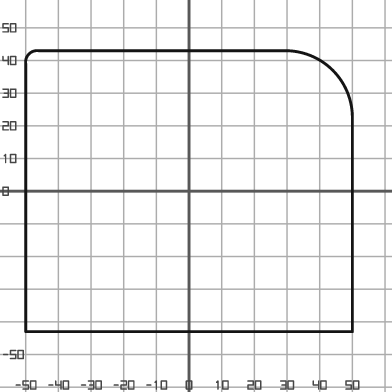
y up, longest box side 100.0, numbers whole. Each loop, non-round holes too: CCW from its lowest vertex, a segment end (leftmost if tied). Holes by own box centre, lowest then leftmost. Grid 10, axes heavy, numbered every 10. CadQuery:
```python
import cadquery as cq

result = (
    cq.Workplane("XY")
    .moveTo(-50.0, -43.0)
    .lineTo(50.0, -43.0)
    .lineTo(50.0, 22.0)
    .threePointArc((44.0, 37.0), (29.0, 43.0))
    .lineTo(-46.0, 43.0)
    .threePointArc((-49.0, 42.0), (-50.0, 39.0))
    .close()
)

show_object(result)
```